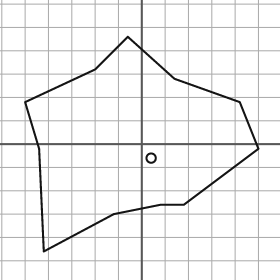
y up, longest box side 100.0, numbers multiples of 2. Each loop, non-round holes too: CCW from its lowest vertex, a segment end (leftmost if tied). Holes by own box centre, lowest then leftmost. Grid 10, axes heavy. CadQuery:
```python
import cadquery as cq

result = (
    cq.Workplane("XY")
    .moveTo(-42.0, -46.0)
    .lineTo(-12.0, -30.0)
    .lineTo(8.0, -26.0)
    .lineTo(18.0, -26.0)
    .lineTo(50.0, -2.0)
    .lineTo(42.0, 18.0)
    .lineTo(14.0, 28.0)
    .lineTo(-6.0, 46.0)
    .lineTo(-20.0, 32.0)
    .lineTo(-50.0, 18.0)
    .lineTo(-44.0, -2.0)
    .close()
    .moveTo(4.0, -6.0)
    .circle(2.0)
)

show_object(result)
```